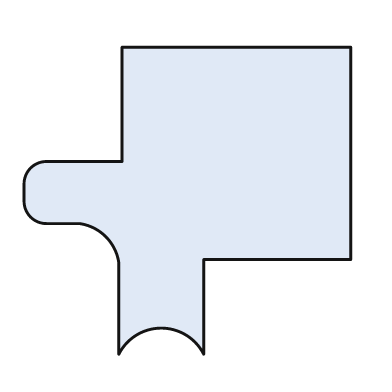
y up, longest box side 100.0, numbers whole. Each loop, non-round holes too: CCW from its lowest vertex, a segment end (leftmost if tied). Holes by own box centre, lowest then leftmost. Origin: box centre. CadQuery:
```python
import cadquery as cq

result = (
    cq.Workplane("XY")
    .moveTo(-21.0, -47.0)
    .threePointArc((-8.0, -39.0), (5.0, -47.0))
    .lineTo(5.0, -18.0)
    .lineTo(50.0, -18.0)
    .lineTo(50.0, 47.0)
    .lineTo(-20.0, 47.0)
    .lineTo(-20.0, 12.0)
    .lineTo(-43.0, 12.0)
    .threePointArc((-48.0, 10.0), (-50.0, 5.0))
    .lineTo(-50.0, 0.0)
    .threePointArc((-48.0, -5.0), (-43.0, -7.0))
    .lineTo(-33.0, -7.0)
    .threePointArc((-25.0, -11.0), (-21.0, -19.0))
    .close()
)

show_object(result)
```